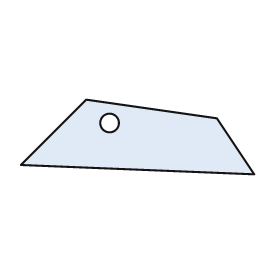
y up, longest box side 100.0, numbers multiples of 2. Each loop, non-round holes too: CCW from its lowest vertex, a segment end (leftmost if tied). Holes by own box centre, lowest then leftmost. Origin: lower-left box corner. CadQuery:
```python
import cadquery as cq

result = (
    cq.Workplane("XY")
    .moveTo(100.0, 0.0)
    .lineTo(84.0, 24.0)
    .lineTo(28.0, 32.0)
    .lineTo(0.0, 4.0)
    .close()
    .moveTo(38.0, 22.0)
    .circle(4.0)
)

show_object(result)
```